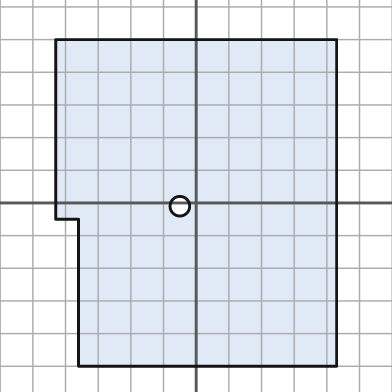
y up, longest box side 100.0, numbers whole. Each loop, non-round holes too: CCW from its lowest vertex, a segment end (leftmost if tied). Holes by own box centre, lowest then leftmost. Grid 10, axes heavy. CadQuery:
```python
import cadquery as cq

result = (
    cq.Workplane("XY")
    .moveTo(-36.0, -50.0)
    .lineTo(43.0, -50.0)
    .lineTo(43.0, 50.0)
    .lineTo(-43.0, 50.0)
    .lineTo(-43.0, -5.0)
    .lineTo(-36.0, -5.0)
    .close()
    .moveTo(-5.0, -1.0)
    .circle(3.0)
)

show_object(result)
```